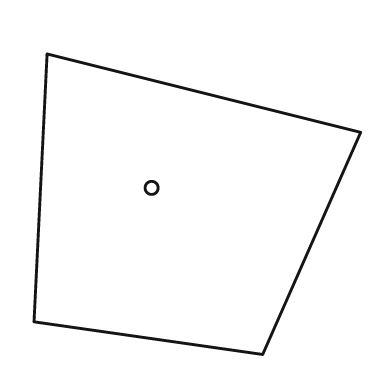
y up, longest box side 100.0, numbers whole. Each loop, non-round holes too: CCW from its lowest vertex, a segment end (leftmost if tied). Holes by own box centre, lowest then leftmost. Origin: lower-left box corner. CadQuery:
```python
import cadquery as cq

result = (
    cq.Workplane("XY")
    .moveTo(70.0, 0.0)
    .lineTo(100.0, 68.0)
    .lineTo(4.0, 92.0)
    .lineTo(0.0, 10.0)
    .close()
    .moveTo(36.0, 51.0)
    .circle(2.0)
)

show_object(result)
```